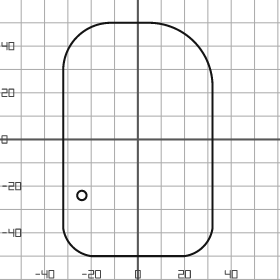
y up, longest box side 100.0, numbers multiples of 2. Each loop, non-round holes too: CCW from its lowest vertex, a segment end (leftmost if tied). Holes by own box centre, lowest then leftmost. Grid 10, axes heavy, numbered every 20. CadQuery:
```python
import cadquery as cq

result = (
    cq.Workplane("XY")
    .moveTo(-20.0, -50.0)
    .lineTo(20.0, -50.0)
    .threePointArc((28.0, -46.0), (32.0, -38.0))
    .lineTo(32.0, 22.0)
    .threePointArc((24.0, 42.0), (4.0, 50.0))
    .lineTo(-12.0, 50.0)
    .threePointArc((-26.0, 44.0), (-32.0, 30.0))
    .lineTo(-32.0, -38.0)
    .threePointArc((-28.0, -46.0), (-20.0, -50.0))
    .close()
    .moveTo(-24.0, -24.0)
    .circle(2.0)
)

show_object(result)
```